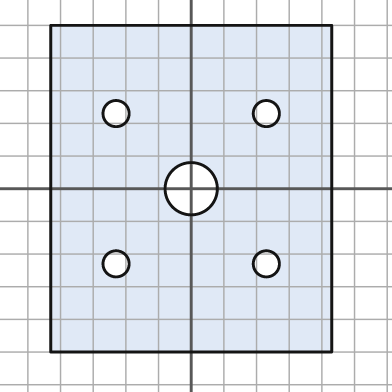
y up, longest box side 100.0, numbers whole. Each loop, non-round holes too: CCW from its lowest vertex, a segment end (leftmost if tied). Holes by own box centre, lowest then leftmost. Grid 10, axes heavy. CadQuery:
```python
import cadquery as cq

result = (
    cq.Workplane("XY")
    .moveTo(-43.0, -50.0)
    .lineTo(43.0, -50.0)
    .lineTo(43.0, 50.0)
    .lineTo(-43.0, 50.0)
    .close()
    .moveTo(-23.0, -23.0)
    .circle(4.0)
    .moveTo(23.0, -23.0)
    .circle(4.0)
    .moveTo(0.0, 0.0)
    .circle(8.0)
    .moveTo(-23.0, 23.0)
    .circle(4.0)
    .moveTo(23.0, 23.0)
    .circle(4.0)
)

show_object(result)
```